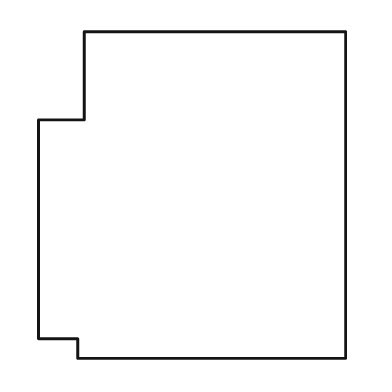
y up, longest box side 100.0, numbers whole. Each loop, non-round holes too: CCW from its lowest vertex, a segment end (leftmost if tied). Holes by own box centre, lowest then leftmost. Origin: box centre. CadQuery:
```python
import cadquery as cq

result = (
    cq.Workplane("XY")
    .moveTo(-35.0, -50.0)
    .lineTo(47.0, -50.0)
    .lineTo(47.0, 50.0)
    .lineTo(-33.0, 50.0)
    .lineTo(-33.0, 23.0)
    .lineTo(-47.0, 23.0)
    .lineTo(-47.0, -44.0)
    .lineTo(-35.0, -44.0)
    .close()
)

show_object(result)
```